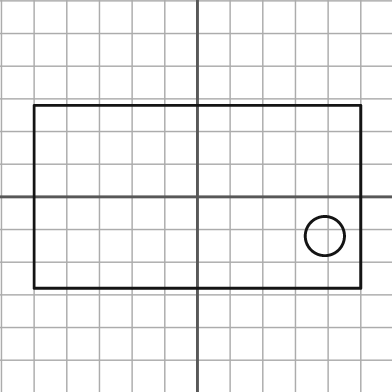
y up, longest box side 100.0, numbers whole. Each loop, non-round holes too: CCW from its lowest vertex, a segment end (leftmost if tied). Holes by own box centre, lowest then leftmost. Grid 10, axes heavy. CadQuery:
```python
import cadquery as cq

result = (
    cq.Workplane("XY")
    .moveTo(-50.0, -28.0)
    .lineTo(50.0, -28.0)
    .lineTo(50.0, 28.0)
    .lineTo(-50.0, 28.0)
    .close()
    .moveTo(39.0, -12.0)
    .circle(6.0)
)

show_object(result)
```